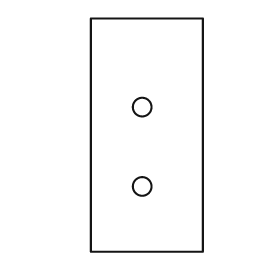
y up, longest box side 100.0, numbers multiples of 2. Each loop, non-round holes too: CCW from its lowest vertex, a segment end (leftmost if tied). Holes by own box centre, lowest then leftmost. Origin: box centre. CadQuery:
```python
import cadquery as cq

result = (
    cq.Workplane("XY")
    .moveTo(-24.0, -50.0)
    .lineTo(24.0, -50.0)
    .lineTo(24.0, 50.0)
    .lineTo(-24.0, 50.0)
    .close()
    .moveTo(-2.0, -22.0)
    .circle(4.0)
    .moveTo(-2.0, 12.0)
    .circle(4.0)
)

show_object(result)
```